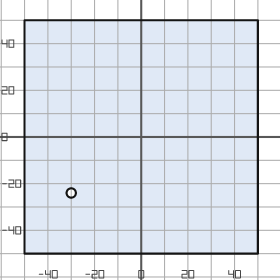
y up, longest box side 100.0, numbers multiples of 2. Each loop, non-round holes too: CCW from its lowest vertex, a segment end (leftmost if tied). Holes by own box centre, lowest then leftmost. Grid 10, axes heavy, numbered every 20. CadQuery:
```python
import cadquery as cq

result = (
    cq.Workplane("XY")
    .moveTo(-50.0, -50.0)
    .lineTo(50.0, -50.0)
    .lineTo(50.0, 50.0)
    .lineTo(-50.0, 50.0)
    .close()
    .moveTo(-30.0, -24.0)
    .circle(2.0)
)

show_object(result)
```